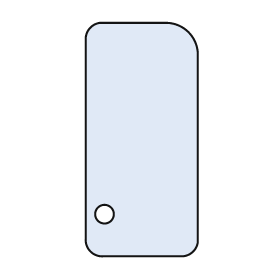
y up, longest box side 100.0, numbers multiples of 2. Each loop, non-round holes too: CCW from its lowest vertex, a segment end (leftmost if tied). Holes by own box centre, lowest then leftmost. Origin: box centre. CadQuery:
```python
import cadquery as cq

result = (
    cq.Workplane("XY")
    .moveTo(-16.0, -50.0)
    .lineTo(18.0, -50.0)
    .threePointArc((22.0, -48.0), (24.0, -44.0))
    .lineTo(24.0, 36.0)
    .threePointArc((20.0, 46.0), (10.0, 50.0))
    .lineTo(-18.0, 50.0)
    .threePointArc((-22.0, 48.0), (-24.0, 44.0))
    .lineTo(-24.0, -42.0)
    .threePointArc((-22.0, -48.0), (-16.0, -50.0))
    .close()
    .moveTo(-16.0, -32.0)
    .circle(4.0)
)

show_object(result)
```